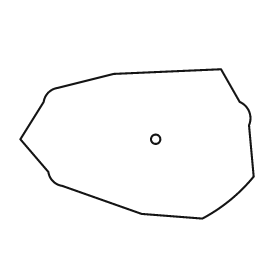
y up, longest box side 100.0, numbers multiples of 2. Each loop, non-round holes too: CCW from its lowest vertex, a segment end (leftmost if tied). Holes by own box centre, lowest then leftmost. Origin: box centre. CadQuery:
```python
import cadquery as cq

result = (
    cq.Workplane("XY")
    .moveTo(28.0, -32.0)
    .threePointArc((40.0, -24.0), (50.0, -14.0))
    .lineTo(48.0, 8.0)
    .threePointArc((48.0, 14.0), (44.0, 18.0))
    .lineTo(36.0, 32.0)
    .lineTo(-10.0, 30.0)
    .lineTo(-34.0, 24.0)
    .threePointArc((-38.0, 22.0), (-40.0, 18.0))
    .lineTo(-50.0, 2.0)
    .lineTo(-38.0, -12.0)
    .threePointArc((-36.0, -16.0), (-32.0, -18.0))
    .lineTo(2.0, -30.0)
    .close()
    .moveTo(8.0, 2.0)
    .circle(2.0)
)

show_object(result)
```